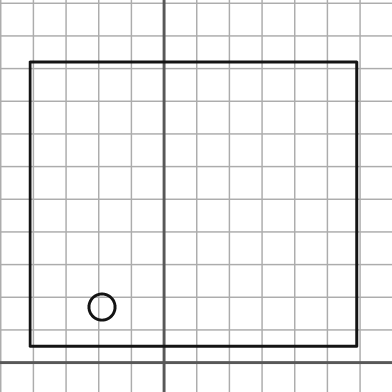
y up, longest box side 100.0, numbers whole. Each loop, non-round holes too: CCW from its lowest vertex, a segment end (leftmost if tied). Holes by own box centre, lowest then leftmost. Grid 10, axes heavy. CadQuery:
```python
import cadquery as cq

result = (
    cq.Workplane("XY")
    .moveTo(-41.0, 5.0)
    .lineTo(59.0, 5.0)
    .lineTo(59.0, 92.0)
    .lineTo(-41.0, 92.0)
    .close()
    .moveTo(-19.0, 17.0)
    .circle(4.0)
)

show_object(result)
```